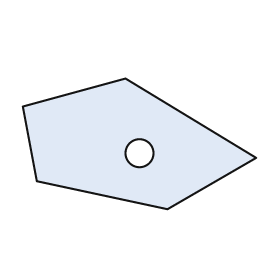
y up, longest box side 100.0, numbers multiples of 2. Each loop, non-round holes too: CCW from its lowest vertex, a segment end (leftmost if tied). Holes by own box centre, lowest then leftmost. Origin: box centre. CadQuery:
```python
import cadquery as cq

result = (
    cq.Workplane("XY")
    .moveTo(12.0, -28.0)
    .lineTo(50.0, -6.0)
    .lineTo(-6.0, 28.0)
    .lineTo(-50.0, 16.0)
    .lineTo(-44.0, -16.0)
    .close()
    .moveTo(0.0, -4.0)
    .circle(6.0)
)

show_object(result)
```